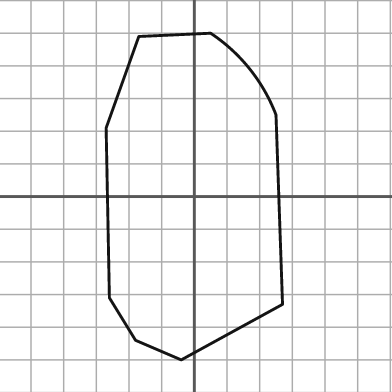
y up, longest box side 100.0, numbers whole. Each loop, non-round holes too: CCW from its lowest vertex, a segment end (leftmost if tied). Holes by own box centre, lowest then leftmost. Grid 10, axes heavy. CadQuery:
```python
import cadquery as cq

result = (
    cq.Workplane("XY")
    .moveTo(-4.0, -50.0)
    .lineTo(27.0, -33.0)
    .lineTo(25.0, 25.0)
    .threePointArc((17.0, 39.0), (5.0, 50.0))
    .lineTo(-17.0, 49.0)
    .lineTo(-27.0, 21.0)
    .lineTo(-26.0, -31.0)
    .lineTo(-18.0, -44.0)
    .close()
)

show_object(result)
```